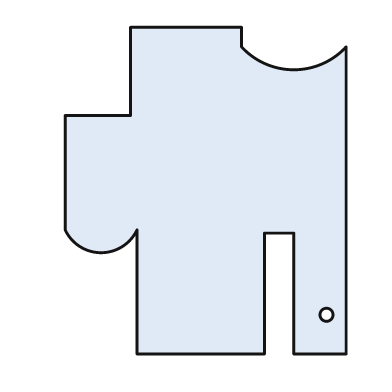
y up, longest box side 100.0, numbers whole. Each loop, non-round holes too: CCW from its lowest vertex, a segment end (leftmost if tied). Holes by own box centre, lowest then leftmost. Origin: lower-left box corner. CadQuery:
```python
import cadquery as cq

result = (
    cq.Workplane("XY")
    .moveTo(22.0, 0.0)
    .lineTo(61.0, 0.0)
    .lineTo(61.0, 37.0)
    .lineTo(70.0, 37.0)
    .lineTo(70.0, 0.0)
    .lineTo(86.0, 0.0)
    .lineTo(86.0, 94.0)
    .threePointArc((70.0, 87.0), (54.0, 94.0))
    .lineTo(54.0, 100.0)
    .lineTo(20.0, 100.0)
    .lineTo(20.0, 73.0)
    .lineTo(0.0, 73.0)
    .lineTo(0.0, 38.0)
    .threePointArc((11.0, 31.0), (22.0, 38.0))
    .close()
    .moveTo(80.0, 12.0)
    .circle(2.0)
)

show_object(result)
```